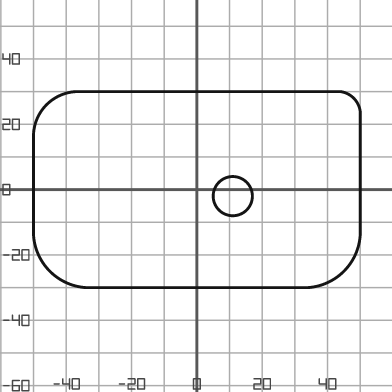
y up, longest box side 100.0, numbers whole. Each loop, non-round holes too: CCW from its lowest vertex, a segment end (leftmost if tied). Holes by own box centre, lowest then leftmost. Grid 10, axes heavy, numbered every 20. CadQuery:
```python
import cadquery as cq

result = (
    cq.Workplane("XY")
    .moveTo(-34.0, -30.0)
    .lineTo(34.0, -30.0)
    .threePointArc((45.0, -25.0), (50.0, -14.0))
    .lineTo(50.0, 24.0)
    .threePointArc((48.0, 28.0), (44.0, 30.0))
    .lineTo(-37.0, 30.0)
    .threePointArc((-46.0, 26.0), (-50.0, 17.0))
    .lineTo(-50.0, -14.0)
    .threePointArc((-45.0, -25.0), (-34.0, -30.0))
    .close()
    .moveTo(11.0, -2.0)
    .circle(6.0)
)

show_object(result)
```